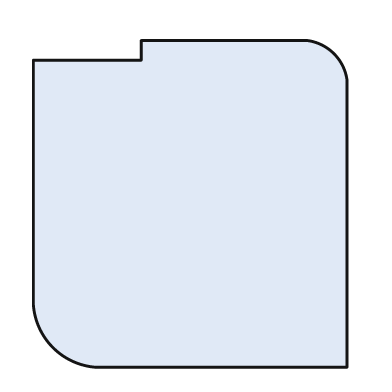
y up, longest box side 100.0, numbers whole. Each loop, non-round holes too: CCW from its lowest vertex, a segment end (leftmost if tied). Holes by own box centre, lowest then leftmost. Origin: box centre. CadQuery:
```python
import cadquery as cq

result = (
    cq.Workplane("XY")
    .moveTo(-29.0, -50.0)
    .lineTo(48.0, -50.0)
    .lineTo(48.0, 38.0)
    .threePointArc((44.0, 46.0), (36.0, 50.0))
    .lineTo(-15.0, 50.0)
    .lineTo(-15.0, 44.0)
    .lineTo(-48.0, 44.0)
    .lineTo(-48.0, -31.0)
    .threePointArc((-42.0, -44.0), (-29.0, -50.0))
    .close()
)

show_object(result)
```